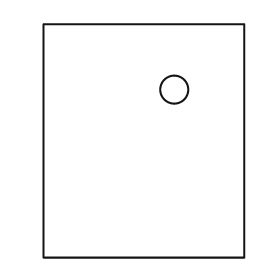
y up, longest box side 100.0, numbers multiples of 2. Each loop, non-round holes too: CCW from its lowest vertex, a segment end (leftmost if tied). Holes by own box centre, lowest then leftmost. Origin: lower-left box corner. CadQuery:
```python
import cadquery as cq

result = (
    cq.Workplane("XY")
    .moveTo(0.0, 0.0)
    .lineTo(86.0, 0.0)
    .lineTo(86.0, 100.0)
    .lineTo(0.0, 100.0)
    .close()
    .moveTo(56.0, 72.0)
    .circle(6.0)
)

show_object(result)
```